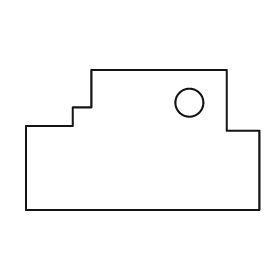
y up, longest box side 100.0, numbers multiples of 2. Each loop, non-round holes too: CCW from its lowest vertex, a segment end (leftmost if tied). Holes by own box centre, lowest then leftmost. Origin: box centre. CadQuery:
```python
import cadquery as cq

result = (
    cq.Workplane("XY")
    .moveTo(-50.0, -30.0)
    .lineTo(50.0, -30.0)
    .lineTo(50.0, 4.0)
    .lineTo(36.0, 4.0)
    .lineTo(36.0, 30.0)
    .lineTo(-22.0, 30.0)
    .lineTo(-22.0, 14.0)
    .lineTo(-30.0, 14.0)
    .lineTo(-30.0, 6.0)
    .lineTo(-50.0, 6.0)
    .close()
    .moveTo(20.0, 16.0)
    .circle(6.0)
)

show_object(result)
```